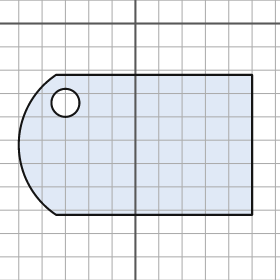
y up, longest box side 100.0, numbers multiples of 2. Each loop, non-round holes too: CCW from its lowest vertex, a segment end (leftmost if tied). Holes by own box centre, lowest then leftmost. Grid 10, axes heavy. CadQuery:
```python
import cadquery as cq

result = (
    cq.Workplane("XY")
    .moveTo(-34.0, -82.0)
    .lineTo(50.0, -82.0)
    .lineTo(50.0, -22.0)
    .lineTo(-34.0, -22.0)
    .threePointArc((-50.0, -52.0), (-34.0, -82.0))
    .close()
    .moveTo(-30.0, -34.0)
    .circle(6.0)
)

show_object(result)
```